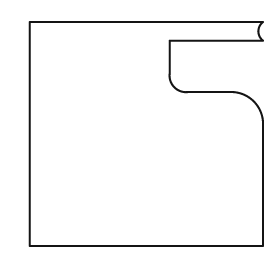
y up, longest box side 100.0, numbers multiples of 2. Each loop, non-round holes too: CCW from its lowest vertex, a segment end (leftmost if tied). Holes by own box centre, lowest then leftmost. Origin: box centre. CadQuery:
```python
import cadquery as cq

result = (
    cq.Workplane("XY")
    .moveTo(-50.0, -48.0)
    .lineTo(50.0, -48.0)
    .lineTo(50.0, 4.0)
    .threePointArc((46.0, 14.0), (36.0, 18.0))
    .lineTo(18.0, 18.0)
    .threePointArc((12.0, 20.0), (10.0, 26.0))
    .lineTo(10.0, 40.0)
    .lineTo(50.0, 40.0)
    .threePointArc((48.0, 44.0), (50.0, 48.0))
    .lineTo(-50.0, 48.0)
    .close()
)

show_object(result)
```